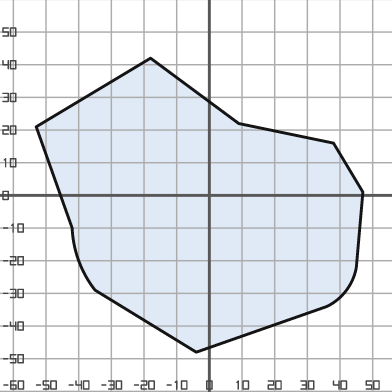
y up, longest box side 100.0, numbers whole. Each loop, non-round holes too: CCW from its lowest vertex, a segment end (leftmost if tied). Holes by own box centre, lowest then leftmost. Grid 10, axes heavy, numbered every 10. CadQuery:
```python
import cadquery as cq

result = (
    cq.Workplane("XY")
    .moveTo(-4.0, -48.0)
    .lineTo(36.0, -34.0)
    .threePointArc((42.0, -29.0), (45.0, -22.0))
    .lineTo(47.0, 1.0)
    .lineTo(38.0, 16.0)
    .lineTo(9.0, 22.0)
    .lineTo(-18.0, 42.0)
    .lineTo(-53.0, 21.0)
    .lineTo(-42.0, -10.0)
    .threePointArc((-40.0, -20.0), (-35.0, -29.0))
    .close()
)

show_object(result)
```